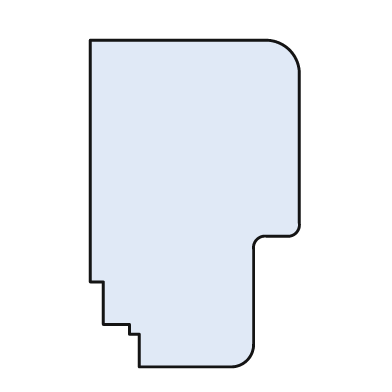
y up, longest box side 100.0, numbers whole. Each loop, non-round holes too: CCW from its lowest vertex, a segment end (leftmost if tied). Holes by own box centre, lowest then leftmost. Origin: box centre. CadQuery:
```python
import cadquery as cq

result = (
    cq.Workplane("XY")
    .moveTo(-17.0, -50.0)
    .lineTo(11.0, -50.0)
    .threePointArc((16.0, -48.0), (18.0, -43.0))
    .lineTo(18.0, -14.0)
    .threePointArc((19.0, -11.0), (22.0, -10.0))
    .lineTo(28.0, -10.0)
    .threePointArc((31.0, -9.0), (32.0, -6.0))
    .lineTo(32.0, 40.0)
    .threePointArc((29.0, 47.0), (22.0, 50.0))
    .lineTo(-32.0, 50.0)
    .lineTo(-32.0, -24.0)
    .lineTo(-28.0, -24.0)
    .lineTo(-28.0, -37.0)
    .lineTo(-20.0, -37.0)
    .lineTo(-20.0, -40.0)
    .lineTo(-17.0, -40.0)
    .close()
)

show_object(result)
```